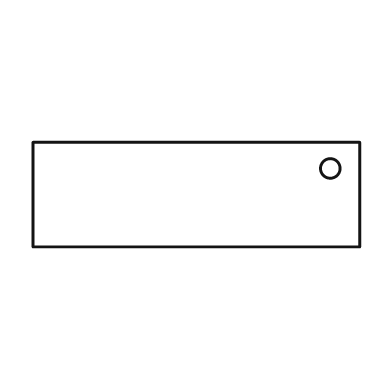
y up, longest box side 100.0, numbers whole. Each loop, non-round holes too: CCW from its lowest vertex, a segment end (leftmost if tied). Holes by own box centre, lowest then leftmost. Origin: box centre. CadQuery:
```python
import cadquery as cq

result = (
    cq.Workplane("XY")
    .moveTo(-50.0, -16.0)
    .lineTo(50.0, -16.0)
    .lineTo(50.0, 16.0)
    .lineTo(-50.0, 16.0)
    .close()
    .moveTo(41.0, 8.0)
    .circle(3.0)
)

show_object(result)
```